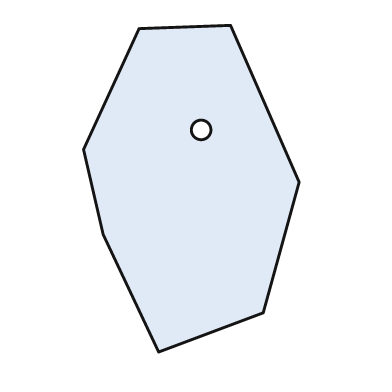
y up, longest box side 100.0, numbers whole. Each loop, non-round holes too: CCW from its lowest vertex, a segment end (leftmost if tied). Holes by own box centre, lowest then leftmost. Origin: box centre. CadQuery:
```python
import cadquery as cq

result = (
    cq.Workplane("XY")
    .moveTo(-10.0, -50.0)
    .lineTo(22.0, -38.0)
    .lineTo(33.0, 2.0)
    .lineTo(12.0, 50.0)
    .lineTo(-16.0, 49.0)
    .lineTo(-33.0, 12.0)
    .lineTo(-27.0, -14.0)
    .close()
    .moveTo(3.0, 18.0)
    .circle(3.0)
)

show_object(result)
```